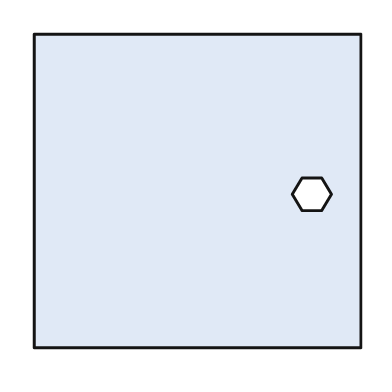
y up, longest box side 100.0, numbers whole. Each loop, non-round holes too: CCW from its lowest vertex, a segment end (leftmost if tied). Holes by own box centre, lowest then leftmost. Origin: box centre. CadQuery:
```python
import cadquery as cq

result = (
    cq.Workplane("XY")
    .moveTo(-50.0, -48.0)
    .lineTo(50.0, -48.0)
    .lineTo(50.0, 48.0)
    .lineTo(-50.0, 48.0)
    .close()
    .moveTo(32.0, -6.0)
    .lineTo(38.0, -6.0)
    .lineTo(41.0, -1.0)
    .lineTo(38.0, 4.0)
    .lineTo(32.0, 4.0)
    .lineTo(29.0, -1.0)
    .close()
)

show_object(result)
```